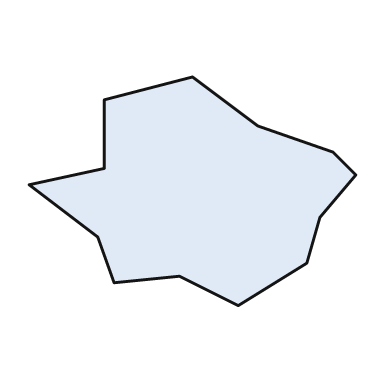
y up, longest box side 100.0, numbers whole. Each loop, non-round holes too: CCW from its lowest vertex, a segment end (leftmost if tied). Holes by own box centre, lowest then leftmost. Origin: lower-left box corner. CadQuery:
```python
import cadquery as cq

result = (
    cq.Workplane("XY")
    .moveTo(64.0, 0.0)
    .lineTo(85.0, 13.0)
    .lineTo(89.0, 27.0)
    .lineTo(100.0, 40.0)
    .lineTo(93.0, 47.0)
    .lineTo(70.0, 55.0)
    .lineTo(50.0, 70.0)
    .lineTo(23.0, 63.0)
    .lineTo(23.0, 42.0)
    .lineTo(0.0, 37.0)
    .lineTo(21.0, 21.0)
    .lineTo(26.0, 7.0)
    .lineTo(46.0, 9.0)
    .close()
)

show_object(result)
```